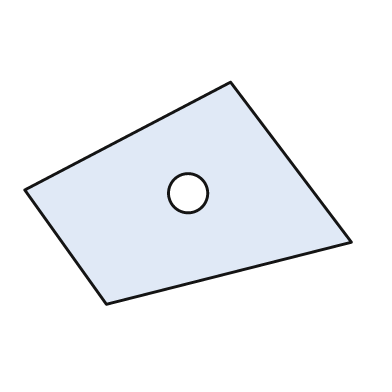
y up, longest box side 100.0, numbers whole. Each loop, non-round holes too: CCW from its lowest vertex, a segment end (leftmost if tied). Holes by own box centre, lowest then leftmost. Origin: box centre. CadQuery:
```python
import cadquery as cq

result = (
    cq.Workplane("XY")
    .moveTo(-25.0, -34.0)
    .lineTo(50.0, -15.0)
    .lineTo(13.0, 34.0)
    .lineTo(-50.0, 1.0)
    .close()
    .moveTo(0.0, 0.0)
    .circle(6.0)
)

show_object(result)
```